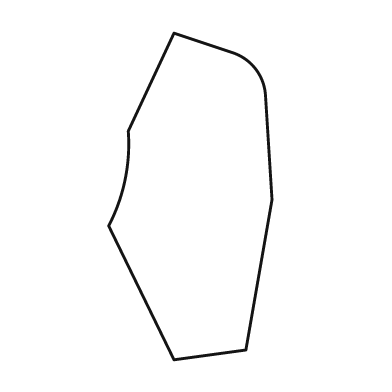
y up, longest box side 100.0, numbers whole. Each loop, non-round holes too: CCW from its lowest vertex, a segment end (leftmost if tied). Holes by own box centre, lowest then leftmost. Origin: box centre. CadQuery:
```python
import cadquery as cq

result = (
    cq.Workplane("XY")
    .moveTo(-5.0, -50.0)
    .lineTo(17.0, -47.0)
    .lineTo(25.0, -1.0)
    .lineTo(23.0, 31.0)
    .threePointArc((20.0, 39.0), (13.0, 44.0))
    .lineTo(-5.0, 50.0)
    .lineTo(-19.0, 20.0)
    .threePointArc((-20.0, 5.0), (-25.0, -9.0))
    .close()
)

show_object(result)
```